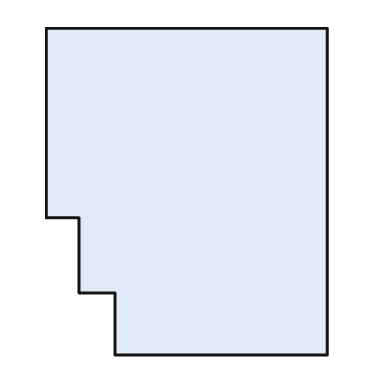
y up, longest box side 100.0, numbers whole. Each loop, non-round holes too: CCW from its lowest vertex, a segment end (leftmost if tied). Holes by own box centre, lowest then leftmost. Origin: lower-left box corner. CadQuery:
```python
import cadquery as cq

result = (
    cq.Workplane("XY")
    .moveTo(21.0, 0.0)
    .lineTo(86.0, 0.0)
    .lineTo(86.0, 100.0)
    .lineTo(0.0, 100.0)
    .lineTo(0.0, 42.0)
    .lineTo(10.0, 42.0)
    .lineTo(10.0, 19.0)
    .lineTo(21.0, 19.0)
    .close()
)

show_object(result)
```